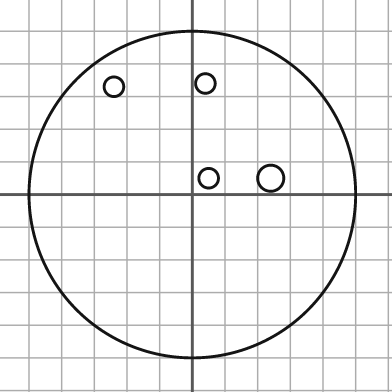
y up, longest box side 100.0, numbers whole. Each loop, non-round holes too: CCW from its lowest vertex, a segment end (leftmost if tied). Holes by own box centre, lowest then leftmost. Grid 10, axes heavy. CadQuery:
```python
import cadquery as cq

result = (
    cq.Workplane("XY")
    .moveTo(0.0, 0.0)
    .circle(50.0)
    .moveTo(5.0, 5.0)
    .circle(3.0)
    .moveTo(24.0, 5.0)
    .circle(4.0)
    .moveTo(-24.0, 33.0)
    .circle(3.0)
    .moveTo(4.0, 34.0)
    .circle(3.0)
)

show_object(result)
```